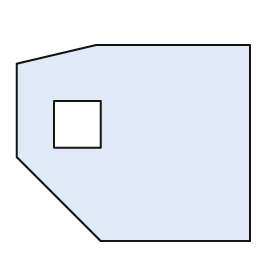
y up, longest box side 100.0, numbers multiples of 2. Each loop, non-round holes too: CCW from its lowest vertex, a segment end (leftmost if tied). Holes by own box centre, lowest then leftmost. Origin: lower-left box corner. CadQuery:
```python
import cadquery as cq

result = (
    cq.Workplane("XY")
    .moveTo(36.0, 0.0)
    .lineTo(100.0, 0.0)
    .lineTo(100.0, 84.0)
    .lineTo(34.0, 84.0)
    .lineTo(0.0, 76.0)
    .lineTo(0.0, 36.0)
    .close()
    .moveTo(16.0, 40.0)
    .lineTo(36.0, 40.0)
    .lineTo(36.0, 60.0)
    .lineTo(16.0, 60.0)
    .close()
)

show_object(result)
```